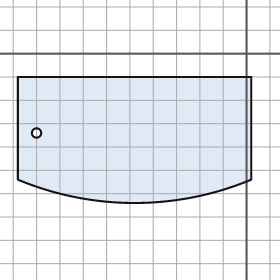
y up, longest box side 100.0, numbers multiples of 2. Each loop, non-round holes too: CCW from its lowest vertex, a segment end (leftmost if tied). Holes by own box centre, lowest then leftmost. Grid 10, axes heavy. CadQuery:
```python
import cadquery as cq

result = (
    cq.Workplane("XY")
    .moveTo(-98.0, -54.0)
    .threePointArc((-48.0, -64.0), (2.0, -54.0))
    .lineTo(2.0, -10.0)
    .lineTo(-98.0, -10.0)
    .close()
    .moveTo(-90.0, -34.0)
    .circle(2.0)
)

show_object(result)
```